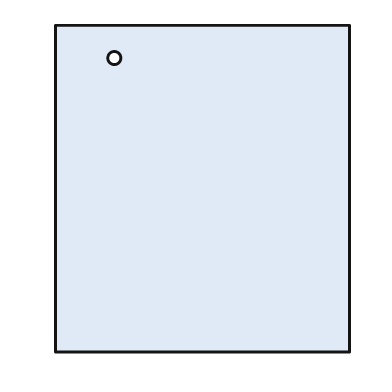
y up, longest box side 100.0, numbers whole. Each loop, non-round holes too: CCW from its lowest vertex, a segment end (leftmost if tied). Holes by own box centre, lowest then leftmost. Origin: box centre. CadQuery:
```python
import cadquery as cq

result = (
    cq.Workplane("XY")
    .moveTo(-45.0, -50.0)
    .lineTo(45.0, -50.0)
    .lineTo(45.0, 50.0)
    .lineTo(-45.0, 50.0)
    .close()
    .moveTo(-27.0, 40.0)
    .circle(2.0)
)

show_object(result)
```